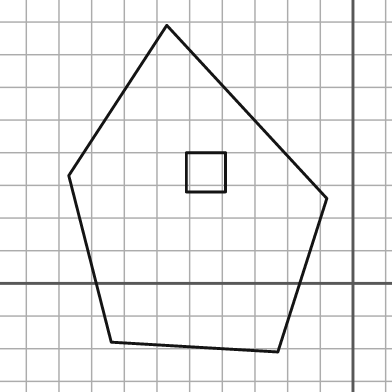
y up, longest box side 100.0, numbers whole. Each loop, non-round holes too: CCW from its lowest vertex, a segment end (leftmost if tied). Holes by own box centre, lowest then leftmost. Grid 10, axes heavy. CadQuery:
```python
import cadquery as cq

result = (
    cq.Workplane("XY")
    .moveTo(-23.0, -21.0)
    .lineTo(-8.0, 26.0)
    .lineTo(-57.0, 79.0)
    .lineTo(-87.0, 33.0)
    .lineTo(-74.0, -18.0)
    .close()
    .moveTo(-51.0, 28.0)
    .lineTo(-39.0, 28.0)
    .lineTo(-39.0, 40.0)
    .lineTo(-51.0, 40.0)
    .close()
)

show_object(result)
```